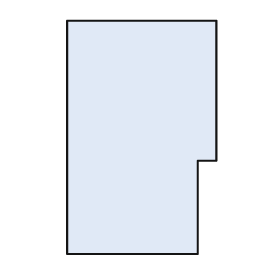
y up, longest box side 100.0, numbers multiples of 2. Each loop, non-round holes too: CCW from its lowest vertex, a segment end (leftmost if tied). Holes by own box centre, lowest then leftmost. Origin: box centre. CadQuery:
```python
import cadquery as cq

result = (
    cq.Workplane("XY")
    .moveTo(-32.0, -50.0)
    .lineTo(24.0, -50.0)
    .lineTo(24.0, -10.0)
    .lineTo(32.0, -10.0)
    .lineTo(32.0, 50.0)
    .lineTo(-32.0, 50.0)
    .close()
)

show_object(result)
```